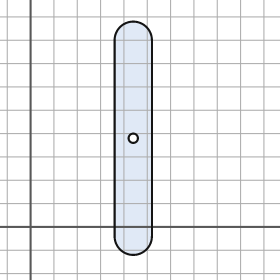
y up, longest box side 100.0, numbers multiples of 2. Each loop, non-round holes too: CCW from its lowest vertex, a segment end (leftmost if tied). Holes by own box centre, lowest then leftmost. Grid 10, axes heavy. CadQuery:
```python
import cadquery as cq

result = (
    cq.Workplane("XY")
    .moveTo(36.0, -4.0)
    .threePointArc((44.0, -12.0), (52.0, -4.0))
    .lineTo(52.0, 80.0)
    .threePointArc((44.0, 88.0), (36.0, 80.0))
    .close()
    .moveTo(44.0, 38.0)
    .circle(2.0)
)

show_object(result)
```